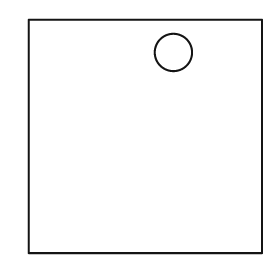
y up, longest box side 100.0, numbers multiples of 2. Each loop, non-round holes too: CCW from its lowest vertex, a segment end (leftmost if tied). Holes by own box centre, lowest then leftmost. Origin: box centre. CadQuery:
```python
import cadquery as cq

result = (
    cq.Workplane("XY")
    .moveTo(-50.0, -50.0)
    .lineTo(50.0, -50.0)
    .lineTo(50.0, 50.0)
    .lineTo(-50.0, 50.0)
    .close()
    .moveTo(12.0, 36.0)
    .circle(8.0)
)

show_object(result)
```